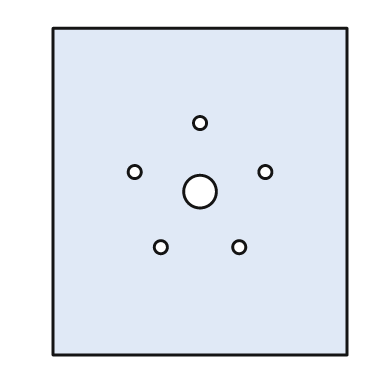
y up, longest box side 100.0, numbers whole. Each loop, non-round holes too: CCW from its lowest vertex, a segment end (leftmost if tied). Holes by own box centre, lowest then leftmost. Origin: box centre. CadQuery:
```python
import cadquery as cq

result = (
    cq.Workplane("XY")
    .moveTo(-45.0, -50.0)
    .lineTo(45.0, -50.0)
    .lineTo(45.0, 50.0)
    .lineTo(-45.0, 50.0)
    .close()
    .moveTo(-12.0, -17.0)
    .circle(2.0)
    .moveTo(12.0, -17.0)
    .circle(2.0)
    .moveTo(0.0, 0.0)
    .circle(5.0)
    .moveTo(-20.0, 6.0)
    .circle(2.0)
    .moveTo(20.0, 6.0)
    .circle(2.0)
    .moveTo(0.0, 21.0)
    .circle(2.0)
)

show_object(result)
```